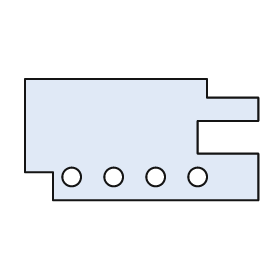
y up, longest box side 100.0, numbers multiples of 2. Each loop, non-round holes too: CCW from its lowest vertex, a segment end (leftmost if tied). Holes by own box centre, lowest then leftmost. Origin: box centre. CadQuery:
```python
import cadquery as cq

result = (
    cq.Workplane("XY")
    .moveTo(-38.0, -26.0)
    .lineTo(50.0, -26.0)
    .lineTo(50.0, -6.0)
    .lineTo(24.0, -6.0)
    .lineTo(24.0, 8.0)
    .lineTo(50.0, 8.0)
    .lineTo(50.0, 18.0)
    .lineTo(28.0, 18.0)
    .lineTo(28.0, 26.0)
    .lineTo(-50.0, 26.0)
    .lineTo(-50.0, -14.0)
    .lineTo(-38.0, -14.0)
    .close()
    .moveTo(-30.0, -16.0)
    .circle(4.0)
    .moveTo(-12.0, -16.0)
    .circle(4.0)
    .moveTo(6.0, -16.0)
    .circle(4.0)
    .moveTo(24.0, -16.0)
    .circle(4.0)
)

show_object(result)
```